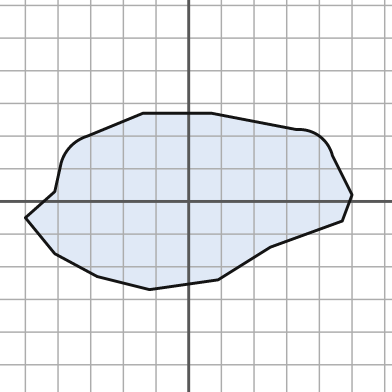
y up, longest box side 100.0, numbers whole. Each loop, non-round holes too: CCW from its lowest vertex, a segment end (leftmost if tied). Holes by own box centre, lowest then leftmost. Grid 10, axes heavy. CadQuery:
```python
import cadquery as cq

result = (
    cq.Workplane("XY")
    .moveTo(-12.0, -27.0)
    .lineTo(9.0, -24.0)
    .lineTo(25.0, -14.0)
    .lineTo(47.0, -6.0)
    .lineTo(50.0, 2.0)
    .lineTo(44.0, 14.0)
    .threePointArc((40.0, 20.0), (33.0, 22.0))
    .lineTo(7.0, 27.0)
    .lineTo(-14.0, 27.0)
    .lineTo(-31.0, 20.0)
    .threePointArc((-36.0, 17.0), (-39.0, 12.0))
    .lineTo(-41.0, 3.0)
    .lineTo(-50.0, -5.0)
    .lineTo(-41.0, -16.0)
    .lineTo(-28.0, -23.0)
    .close()
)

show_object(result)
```